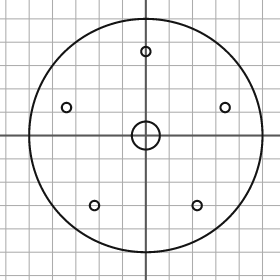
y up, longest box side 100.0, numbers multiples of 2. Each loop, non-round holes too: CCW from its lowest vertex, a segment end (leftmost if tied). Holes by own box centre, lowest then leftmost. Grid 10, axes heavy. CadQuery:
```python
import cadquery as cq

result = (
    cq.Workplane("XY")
    .moveTo(0.0, 0.0)
    .circle(50.0)
    .moveTo(-22.0, -30.0)
    .circle(2.0)
    .moveTo(22.0, -30.0)
    .circle(2.0)
    .moveTo(0.0, 0.0)
    .circle(6.0)
    .moveTo(-34.0, 12.0)
    .circle(2.0)
    .moveTo(34.0, 12.0)
    .circle(2.0)
    .moveTo(0.0, 36.0)
    .circle(2.0)
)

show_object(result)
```